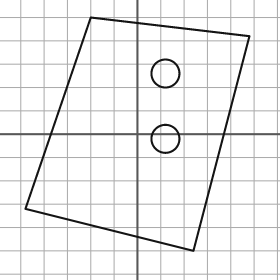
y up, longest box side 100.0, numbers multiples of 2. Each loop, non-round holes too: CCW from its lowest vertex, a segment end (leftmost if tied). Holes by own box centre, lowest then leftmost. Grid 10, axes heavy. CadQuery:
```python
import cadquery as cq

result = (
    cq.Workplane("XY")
    .moveTo(24.0, -50.0)
    .lineTo(48.0, 42.0)
    .lineTo(-20.0, 50.0)
    .lineTo(-48.0, -32.0)
    .close()
    .moveTo(12.0, -2.0)
    .circle(6.0)
    .moveTo(12.0, 26.0)
    .circle(6.0)
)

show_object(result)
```